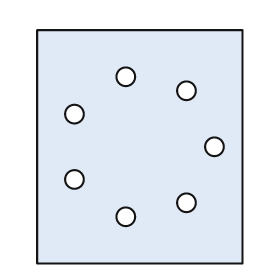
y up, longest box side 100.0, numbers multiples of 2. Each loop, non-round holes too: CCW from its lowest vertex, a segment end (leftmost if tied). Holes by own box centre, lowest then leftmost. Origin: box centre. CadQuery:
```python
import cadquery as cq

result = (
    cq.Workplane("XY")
    .moveTo(-44.0, -50.0)
    .lineTo(44.0, -50.0)
    .lineTo(44.0, 50.0)
    .lineTo(-44.0, 50.0)
    .close()
    .moveTo(-6.0, -30.0)
    .circle(4.0)
    .moveTo(20.0, -24.0)
    .circle(4.0)
    .moveTo(-28.0, -14.0)
    .circle(4.0)
    .moveTo(32.0, 0.0)
    .circle(4.0)
    .moveTo(-28.0, 14.0)
    .circle(4.0)
    .moveTo(20.0, 24.0)
    .circle(4.0)
    .moveTo(-6.0, 30.0)
    .circle(4.0)
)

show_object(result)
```